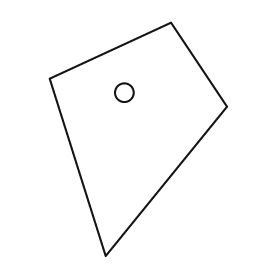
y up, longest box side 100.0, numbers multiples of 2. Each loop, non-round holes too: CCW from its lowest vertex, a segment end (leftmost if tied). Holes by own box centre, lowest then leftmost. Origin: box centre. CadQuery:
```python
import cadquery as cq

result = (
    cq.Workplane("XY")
    .moveTo(-14.0, -50.0)
    .lineTo(38.0, 14.0)
    .lineTo(14.0, 50.0)
    .lineTo(-38.0, 26.0)
    .close()
    .moveTo(-6.0, 20.0)
    .circle(4.0)
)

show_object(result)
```